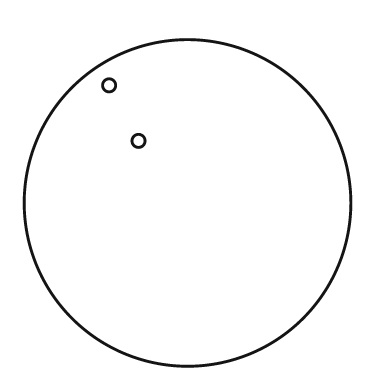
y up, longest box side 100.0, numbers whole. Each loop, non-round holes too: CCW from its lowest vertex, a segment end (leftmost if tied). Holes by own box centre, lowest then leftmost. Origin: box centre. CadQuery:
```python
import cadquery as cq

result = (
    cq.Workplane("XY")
    .moveTo(0.0, 0.0)
    .circle(50.0)
    .moveTo(-15.0, 19.0)
    .circle(2.0)
    .moveTo(-24.0, 36.0)
    .circle(2.0)
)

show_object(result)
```